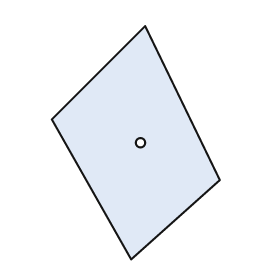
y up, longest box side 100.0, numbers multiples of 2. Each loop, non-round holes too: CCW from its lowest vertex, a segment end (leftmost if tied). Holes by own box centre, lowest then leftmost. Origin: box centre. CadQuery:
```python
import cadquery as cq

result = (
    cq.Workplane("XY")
    .moveTo(-2.0, -50.0)
    .lineTo(36.0, -16.0)
    .lineTo(4.0, 50.0)
    .lineTo(-36.0, 10.0)
    .close()
    .moveTo(2.0, 0.0)
    .circle(2.0)
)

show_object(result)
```